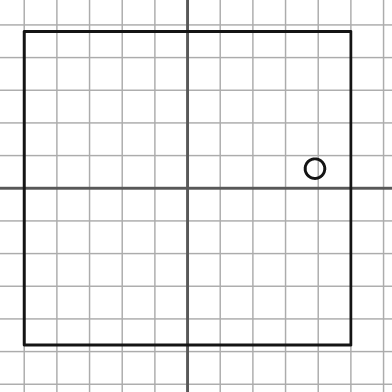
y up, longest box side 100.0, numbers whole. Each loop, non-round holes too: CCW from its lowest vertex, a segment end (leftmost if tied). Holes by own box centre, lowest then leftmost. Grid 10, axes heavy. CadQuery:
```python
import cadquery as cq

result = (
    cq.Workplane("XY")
    .moveTo(-50.0, -48.0)
    .lineTo(50.0, -48.0)
    .lineTo(50.0, 48.0)
    .lineTo(-50.0, 48.0)
    .close()
    .moveTo(39.0, 6.0)
    .circle(3.0)
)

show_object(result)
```